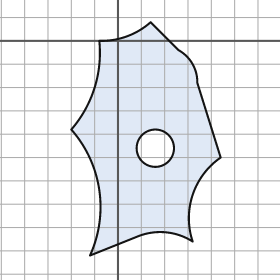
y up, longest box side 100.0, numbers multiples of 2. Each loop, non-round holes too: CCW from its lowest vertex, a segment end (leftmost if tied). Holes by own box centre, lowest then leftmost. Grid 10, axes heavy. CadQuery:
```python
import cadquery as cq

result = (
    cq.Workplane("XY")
    .moveTo(-12.0, -92.0)
    .lineTo(8.0, -84.0)
    .threePointArc((20.0, -82.0), (32.0, -86.0))
    .threePointArc((32.0, -66.0), (44.0, -50.0))
    .lineTo(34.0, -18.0)
    .threePointArc((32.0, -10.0), (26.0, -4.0))
    .lineTo(14.0, 8.0)
    .threePointArc((4.0, 2.0), (-8.0, 0.0))
    .threePointArc((-10.0, -20.0), (-20.0, -38.0))
    .threePointArc((-8.0, -64.0), (-12.0, -92.0))
    .close()
    .moveTo(16.0, -46.0)
    .circle(8.0)
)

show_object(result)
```